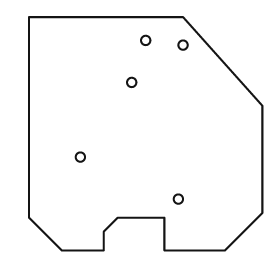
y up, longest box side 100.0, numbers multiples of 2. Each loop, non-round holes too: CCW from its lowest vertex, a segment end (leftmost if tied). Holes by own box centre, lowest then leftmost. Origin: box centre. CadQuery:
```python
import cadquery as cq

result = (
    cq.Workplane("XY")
    .moveTo(-36.0, -50.0)
    .lineTo(-18.0, -50.0)
    .lineTo(-18.0, -42.0)
    .lineTo(-12.0, -36.0)
    .lineTo(8.0, -36.0)
    .lineTo(8.0, -50.0)
    .lineTo(34.0, -50.0)
    .lineTo(50.0, -34.0)
    .lineTo(50.0, 12.0)
    .lineTo(16.0, 50.0)
    .lineTo(-50.0, 50.0)
    .lineTo(-50.0, -36.0)
    .close()
    .moveTo(14.0, -28.0)
    .circle(2.0)
    .moveTo(-28.0, -10.0)
    .circle(2.0)
    .moveTo(-6.0, 22.0)
    .circle(2.0)
    .moveTo(16.0, 38.0)
    .circle(2.0)
    .moveTo(0.0, 40.0)
    .circle(2.0)
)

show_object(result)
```